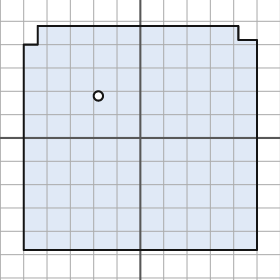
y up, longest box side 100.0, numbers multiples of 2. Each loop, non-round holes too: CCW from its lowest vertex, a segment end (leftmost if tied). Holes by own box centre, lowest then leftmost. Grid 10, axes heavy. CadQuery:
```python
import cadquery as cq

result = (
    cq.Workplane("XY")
    .moveTo(-50.0, -48.0)
    .lineTo(50.0, -48.0)
    .lineTo(50.0, 42.0)
    .lineTo(42.0, 42.0)
    .lineTo(42.0, 48.0)
    .lineTo(-44.0, 48.0)
    .lineTo(-44.0, 40.0)
    .lineTo(-50.0, 40.0)
    .close()
    .moveTo(-18.0, 18.0)
    .circle(2.0)
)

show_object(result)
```